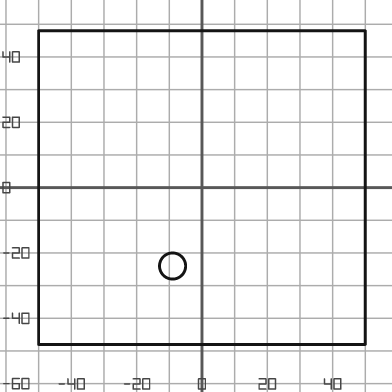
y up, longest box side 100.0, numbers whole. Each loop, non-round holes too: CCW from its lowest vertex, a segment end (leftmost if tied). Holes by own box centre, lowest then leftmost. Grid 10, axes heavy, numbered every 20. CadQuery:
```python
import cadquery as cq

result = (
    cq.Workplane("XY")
    .moveTo(-50.0, -48.0)
    .lineTo(50.0, -48.0)
    .lineTo(50.0, 48.0)
    .lineTo(-50.0, 48.0)
    .close()
    .moveTo(-9.0, -24.0)
    .circle(4.0)
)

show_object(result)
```